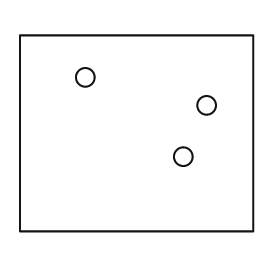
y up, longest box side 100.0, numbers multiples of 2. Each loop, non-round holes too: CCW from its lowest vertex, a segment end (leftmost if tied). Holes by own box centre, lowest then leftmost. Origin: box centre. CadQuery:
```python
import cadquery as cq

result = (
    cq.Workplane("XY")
    .moveTo(-50.0, -42.0)
    .lineTo(50.0, -42.0)
    .lineTo(50.0, 42.0)
    .lineTo(-50.0, 42.0)
    .close()
    .moveTo(20.0, -10.0)
    .circle(4.0)
    .moveTo(30.0, 12.0)
    .circle(4.0)
    .moveTo(-22.0, 24.0)
    .circle(4.0)
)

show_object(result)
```